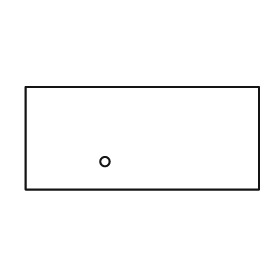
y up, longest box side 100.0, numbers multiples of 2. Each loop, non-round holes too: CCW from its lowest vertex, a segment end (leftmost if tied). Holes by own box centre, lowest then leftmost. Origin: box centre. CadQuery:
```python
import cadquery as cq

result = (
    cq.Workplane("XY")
    .moveTo(-50.0, -22.0)
    .lineTo(50.0, -22.0)
    .lineTo(50.0, 22.0)
    .lineTo(-50.0, 22.0)
    .close()
    .moveTo(-16.0, -10.0)
    .circle(2.0)
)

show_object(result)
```